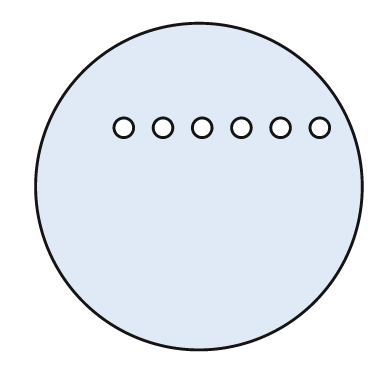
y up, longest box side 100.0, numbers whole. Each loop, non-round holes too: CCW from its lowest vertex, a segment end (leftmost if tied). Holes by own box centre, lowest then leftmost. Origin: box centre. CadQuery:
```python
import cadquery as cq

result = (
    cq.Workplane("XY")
    .moveTo(0.0, 0.0)
    .circle(50.0)
    .moveTo(-23.0, 18.0)
    .circle(3.0)
    .moveTo(-11.0, 18.0)
    .circle(3.0)
    .moveTo(1.0, 18.0)
    .circle(3.0)
    .moveTo(13.0, 18.0)
    .circle(3.0)
    .moveTo(25.0, 18.0)
    .circle(3.0)
    .moveTo(37.0, 18.0)
    .circle(3.0)
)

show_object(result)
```